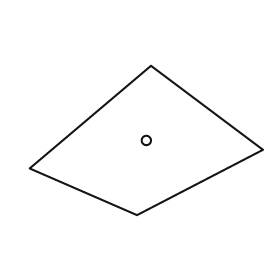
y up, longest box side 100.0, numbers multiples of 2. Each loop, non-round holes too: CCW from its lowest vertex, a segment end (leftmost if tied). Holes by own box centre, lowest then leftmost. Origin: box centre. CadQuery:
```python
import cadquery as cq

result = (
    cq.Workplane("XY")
    .moveTo(-4.0, -32.0)
    .lineTo(50.0, -4.0)
    .lineTo(2.0, 32.0)
    .lineTo(-50.0, -12.0)
    .close()
    .moveTo(0.0, 0.0)
    .circle(2.0)
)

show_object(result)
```